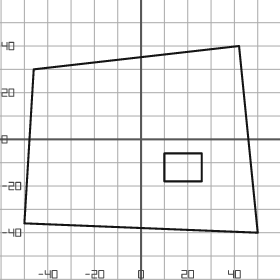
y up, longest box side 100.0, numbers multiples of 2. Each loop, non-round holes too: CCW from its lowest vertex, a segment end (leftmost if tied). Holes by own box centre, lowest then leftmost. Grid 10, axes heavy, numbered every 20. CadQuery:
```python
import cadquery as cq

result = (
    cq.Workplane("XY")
    .moveTo(50.0, -40.0)
    .lineTo(42.0, 40.0)
    .lineTo(-46.0, 30.0)
    .lineTo(-50.0, -36.0)
    .close()
    .moveTo(10.0, -18.0)
    .lineTo(26.0, -18.0)
    .lineTo(26.0, -6.0)
    .lineTo(10.0, -6.0)
    .close()
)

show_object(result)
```